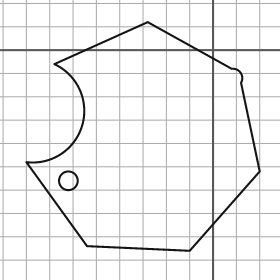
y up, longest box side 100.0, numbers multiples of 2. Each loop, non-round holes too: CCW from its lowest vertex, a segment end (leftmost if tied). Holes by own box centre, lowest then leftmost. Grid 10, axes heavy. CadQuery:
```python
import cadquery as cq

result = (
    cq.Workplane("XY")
    .moveTo(-10.0, -86.0)
    .lineTo(20.0, -52.0)
    .lineTo(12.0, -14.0)
    .threePointArc((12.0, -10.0), (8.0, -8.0))
    .lineTo(-28.0, 12.0)
    .lineTo(-68.0, -6.0)
    .threePointArc((-56.0, -32.0), (-80.0, -48.0))
    .lineTo(-54.0, -84.0)
    .close()
    .moveTo(-62.0, -56.0)
    .circle(4.0)
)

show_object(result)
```